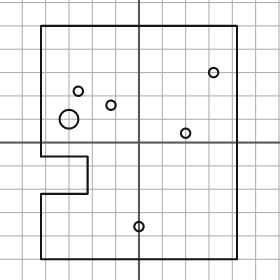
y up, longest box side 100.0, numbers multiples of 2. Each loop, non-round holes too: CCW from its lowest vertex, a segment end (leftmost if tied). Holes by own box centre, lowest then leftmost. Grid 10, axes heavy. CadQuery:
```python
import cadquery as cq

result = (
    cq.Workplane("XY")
    .moveTo(-42.0, -50.0)
    .lineTo(42.0, -50.0)
    .lineTo(42.0, 50.0)
    .lineTo(-42.0, 50.0)
    .lineTo(-42.0, -6.0)
    .lineTo(-22.0, -6.0)
    .lineTo(-22.0, -22.0)
    .lineTo(-42.0, -22.0)
    .close()
    .moveTo(0.0, -36.0)
    .circle(2.0)
    .moveTo(20.0, 4.0)
    .circle(2.0)
    .moveTo(-30.0, 10.0)
    .circle(4.0)
    .moveTo(-12.0, 16.0)
    .circle(2.0)
    .moveTo(-26.0, 22.0)
    .circle(2.0)
    .moveTo(32.0, 30.0)
    .circle(2.0)
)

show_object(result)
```